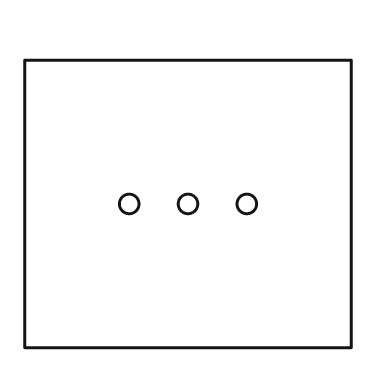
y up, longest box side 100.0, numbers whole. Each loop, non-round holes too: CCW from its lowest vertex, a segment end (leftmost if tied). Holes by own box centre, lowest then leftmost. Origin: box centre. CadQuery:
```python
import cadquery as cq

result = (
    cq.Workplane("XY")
    .moveTo(-50.0, -44.0)
    .lineTo(50.0, -44.0)
    .lineTo(50.0, 44.0)
    .lineTo(-50.0, 44.0)
    .close()
    .moveTo(-18.0, 0.0)
    .circle(3.0)
    .moveTo(0.0, 0.0)
    .circle(3.0)
    .moveTo(18.0, 0.0)
    .circle(3.0)
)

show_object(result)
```